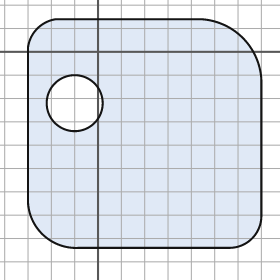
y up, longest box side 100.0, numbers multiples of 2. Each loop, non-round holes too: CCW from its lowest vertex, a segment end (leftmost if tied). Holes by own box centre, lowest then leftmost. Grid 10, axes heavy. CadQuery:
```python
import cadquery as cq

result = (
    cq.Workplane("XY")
    .moveTo(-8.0, -84.0)
    .lineTo(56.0, -84.0)
    .threePointArc((66.0, -80.0), (70.0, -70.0))
    .lineTo(70.0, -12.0)
    .threePointArc((62.0, 6.0), (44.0, 14.0))
    .lineTo(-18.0, 14.0)
    .threePointArc((-26.0, 10.0), (-30.0, 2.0))
    .lineTo(-30.0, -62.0)
    .threePointArc((-24.0, -78.0), (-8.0, -84.0))
    .close()
    .moveTo(-10.0, -22.0)
    .circle(12.0)
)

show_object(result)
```